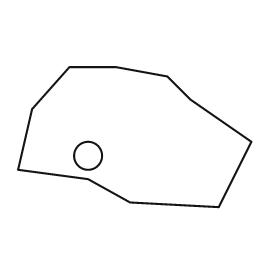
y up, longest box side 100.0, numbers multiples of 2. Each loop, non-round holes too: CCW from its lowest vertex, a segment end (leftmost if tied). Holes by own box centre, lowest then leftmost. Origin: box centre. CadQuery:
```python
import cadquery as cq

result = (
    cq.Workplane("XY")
    .moveTo(36.0, -30.0)
    .lineTo(50.0, -2.0)
    .lineTo(24.0, 16.0)
    .lineTo(14.0, 26.0)
    .lineTo(-8.0, 30.0)
    .lineTo(-28.0, 30.0)
    .lineTo(-44.0, 12.0)
    .lineTo(-50.0, -14.0)
    .lineTo(-20.0, -18.0)
    .lineTo(-2.0, -28.0)
    .close()
    .moveTo(-20.0, -8.0)
    .circle(6.0)
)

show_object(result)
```